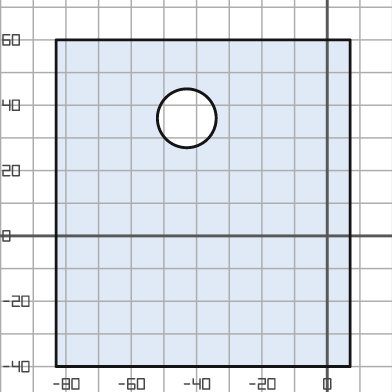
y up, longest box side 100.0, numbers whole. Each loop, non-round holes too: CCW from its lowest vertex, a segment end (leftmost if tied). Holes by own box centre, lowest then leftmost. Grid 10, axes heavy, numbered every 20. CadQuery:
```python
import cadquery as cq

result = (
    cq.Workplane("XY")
    .moveTo(-83.0, -40.0)
    .lineTo(7.0, -40.0)
    .lineTo(7.0, 60.0)
    .lineTo(-83.0, 60.0)
    .close()
    .moveTo(-43.0, 36.0)
    .circle(9.0)
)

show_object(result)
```